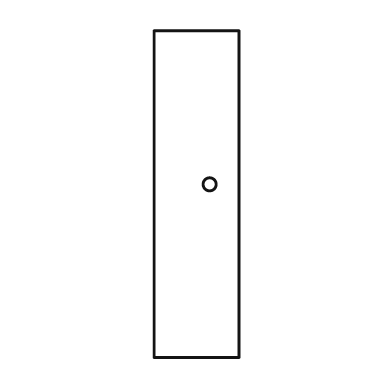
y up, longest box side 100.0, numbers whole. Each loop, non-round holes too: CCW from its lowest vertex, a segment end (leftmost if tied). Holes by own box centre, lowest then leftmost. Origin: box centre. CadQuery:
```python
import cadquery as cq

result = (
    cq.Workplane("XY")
    .moveTo(-13.0, -50.0)
    .lineTo(13.0, -50.0)
    .lineTo(13.0, 50.0)
    .lineTo(-13.0, 50.0)
    .close()
    .moveTo(4.0, 3.0)
    .circle(2.0)
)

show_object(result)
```